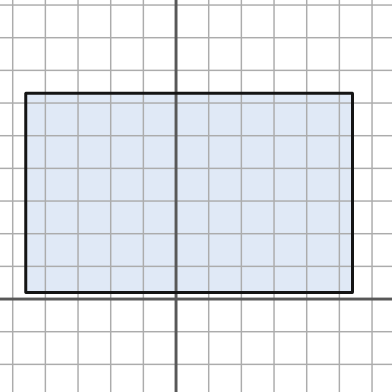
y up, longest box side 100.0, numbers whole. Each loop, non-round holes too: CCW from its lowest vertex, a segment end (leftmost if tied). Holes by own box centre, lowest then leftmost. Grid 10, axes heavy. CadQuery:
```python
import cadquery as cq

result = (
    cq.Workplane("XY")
    .moveTo(-46.0, 2.0)
    .lineTo(54.0, 2.0)
    .lineTo(54.0, 63.0)
    .lineTo(-46.0, 63.0)
    .close()
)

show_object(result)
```